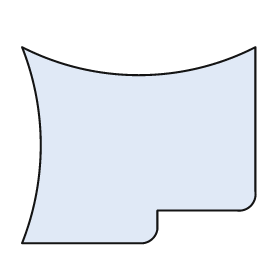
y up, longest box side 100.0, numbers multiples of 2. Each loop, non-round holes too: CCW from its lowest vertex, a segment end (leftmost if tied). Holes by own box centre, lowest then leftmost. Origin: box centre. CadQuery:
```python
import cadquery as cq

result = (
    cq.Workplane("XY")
    .moveTo(-50.0, -42.0)
    .lineTo(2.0, -42.0)
    .threePointArc((6.0, -40.0), (8.0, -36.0))
    .lineTo(8.0, -28.0)
    .lineTo(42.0, -28.0)
    .threePointArc((48.0, -26.0), (50.0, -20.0))
    .lineTo(50.0, 42.0)
    .threePointArc((0.0, 30.0), (-50.0, 42.0))
    .threePointArc((-42.0, 0.0), (-50.0, -42.0))
    .close()
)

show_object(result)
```